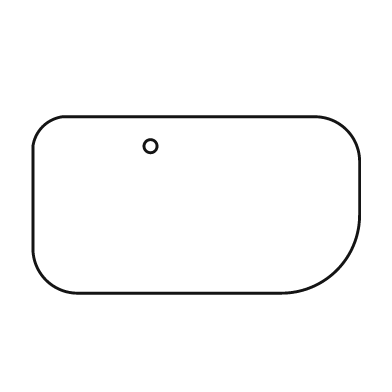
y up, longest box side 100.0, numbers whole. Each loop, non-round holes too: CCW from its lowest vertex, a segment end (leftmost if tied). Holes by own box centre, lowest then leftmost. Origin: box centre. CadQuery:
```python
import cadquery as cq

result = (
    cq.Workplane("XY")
    .moveTo(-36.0, -27.0)
    .lineTo(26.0, -27.0)
    .threePointArc((43.0, -20.0), (50.0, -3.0))
    .lineTo(50.0, 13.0)
    .threePointArc((46.0, 23.0), (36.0, 27.0))
    .lineTo(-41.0, 27.0)
    .threePointArc((-47.0, 24.0), (-50.0, 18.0))
    .lineTo(-50.0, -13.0)
    .threePointArc((-46.0, -23.0), (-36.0, -27.0))
    .close()
    .moveTo(-14.0, 18.0)
    .circle(2.0)
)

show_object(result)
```